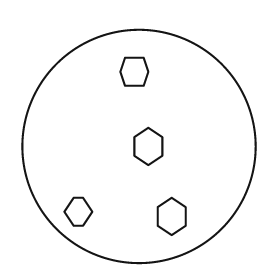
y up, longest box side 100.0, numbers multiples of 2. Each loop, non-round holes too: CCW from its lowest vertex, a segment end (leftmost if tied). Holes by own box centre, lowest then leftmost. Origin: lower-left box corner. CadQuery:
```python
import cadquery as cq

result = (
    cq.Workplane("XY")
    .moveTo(50.0, 50.0)
    .circle(50.0)
    .moveTo(64.0, 12.0)
    .lineTo(70.0, 16.0)
    .lineTo(70.0, 24.0)
    .lineTo(64.0, 28.0)
    .lineTo(58.0, 24.0)
    .lineTo(58.0, 16.0)
    .close()
    .moveTo(22.0, 16.0)
    .lineTo(26.0, 16.0)
    .lineTo(30.0, 22.0)
    .lineTo(26.0, 28.0)
    .lineTo(22.0, 28.0)
    .lineTo(18.0, 22.0)
    .close()
    .moveTo(54.0, 42.0)
    .lineTo(60.0, 46.0)
    .lineTo(60.0, 54.0)
    .lineTo(54.0, 58.0)
    .lineTo(48.0, 54.0)
    .lineTo(48.0, 46.0)
    .close()
    .moveTo(44.0, 76.0)
    .lineTo(52.0, 76.0)
    .lineTo(54.0, 82.0)
    .lineTo(52.0, 88.0)
    .lineTo(44.0, 88.0)
    .lineTo(42.0, 82.0)
    .close()
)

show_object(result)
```